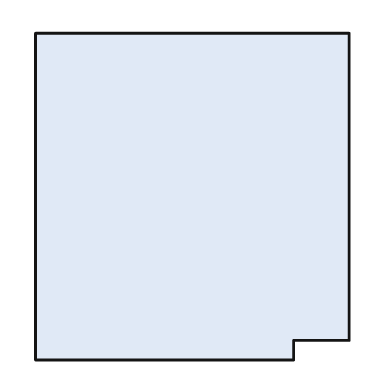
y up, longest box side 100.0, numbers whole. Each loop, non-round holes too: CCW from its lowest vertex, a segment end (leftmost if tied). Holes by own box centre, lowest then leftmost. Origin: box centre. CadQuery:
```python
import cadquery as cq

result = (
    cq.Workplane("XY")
    .moveTo(-48.0, -50.0)
    .lineTo(31.0, -50.0)
    .lineTo(31.0, -44.0)
    .lineTo(48.0, -44.0)
    .lineTo(48.0, 50.0)
    .lineTo(-48.0, 50.0)
    .close()
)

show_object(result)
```